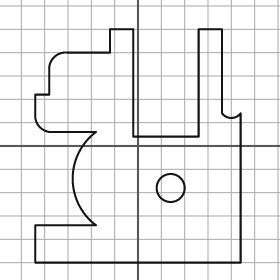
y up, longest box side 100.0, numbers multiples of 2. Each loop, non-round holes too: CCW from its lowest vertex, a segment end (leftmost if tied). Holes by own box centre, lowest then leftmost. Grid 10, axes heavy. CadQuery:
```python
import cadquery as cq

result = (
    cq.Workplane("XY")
    .moveTo(-44.0, -50.0)
    .lineTo(44.0, -50.0)
    .lineTo(44.0, 14.0)
    .threePointArc((40.0, 12.0), (36.0, 14.0))
    .lineTo(36.0, 50.0)
    .lineTo(26.0, 50.0)
    .lineTo(26.0, 4.0)
    .lineTo(-2.0, 4.0)
    .lineTo(-2.0, 50.0)
    .lineTo(-12.0, 50.0)
    .lineTo(-12.0, 40.0)
    .lineTo(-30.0, 40.0)
    .threePointArc((-36.0, 38.0), (-38.0, 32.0))
    .lineTo(-38.0, 22.0)
    .lineTo(-44.0, 22.0)
    .lineTo(-44.0, 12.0)
    .threePointArc((-42.0, 8.0), (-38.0, 6.0))
    .lineTo(-18.0, 6.0)
    .threePointArc((-28.0, -14.0), (-18.0, -34.0))
    .lineTo(-44.0, -34.0)
    .close()
    .moveTo(14.0, -18.0)
    .circle(6.0)
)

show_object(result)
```